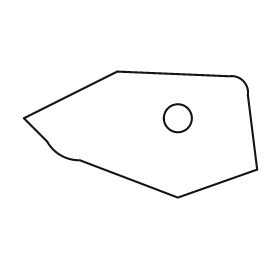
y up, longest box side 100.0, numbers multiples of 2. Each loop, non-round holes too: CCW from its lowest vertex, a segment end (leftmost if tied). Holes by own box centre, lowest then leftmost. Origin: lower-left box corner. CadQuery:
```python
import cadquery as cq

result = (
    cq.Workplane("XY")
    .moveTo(66.0, 0.0)
    .lineTo(100.0, 12.0)
    .lineTo(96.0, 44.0)
    .threePointArc((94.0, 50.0), (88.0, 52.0))
    .lineTo(40.0, 54.0)
    .lineTo(0.0, 34.0)
    .lineTo(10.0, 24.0)
    .threePointArc((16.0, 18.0), (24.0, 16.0))
    .close()
    .moveTo(66.0, 34.0)
    .circle(6.0)
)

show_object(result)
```